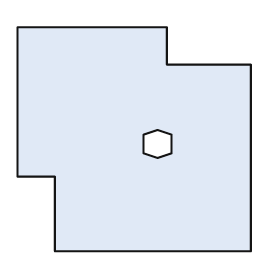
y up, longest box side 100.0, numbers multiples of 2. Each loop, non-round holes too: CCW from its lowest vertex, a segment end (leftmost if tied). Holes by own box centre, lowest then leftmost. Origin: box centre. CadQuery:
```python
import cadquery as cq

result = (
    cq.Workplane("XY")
    .moveTo(-34.0, -48.0)
    .lineTo(50.0, -48.0)
    .lineTo(50.0, 32.0)
    .lineTo(14.0, 32.0)
    .lineTo(14.0, 48.0)
    .lineTo(-50.0, 48.0)
    .lineTo(-50.0, -16.0)
    .lineTo(-34.0, -16.0)
    .close()
    .moveTo(10.0, -8.0)
    .lineTo(16.0, -6.0)
    .lineTo(16.0, 2.0)
    .lineTo(10.0, 4.0)
    .lineTo(4.0, 2.0)
    .lineTo(4.0, -6.0)
    .close()
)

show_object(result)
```